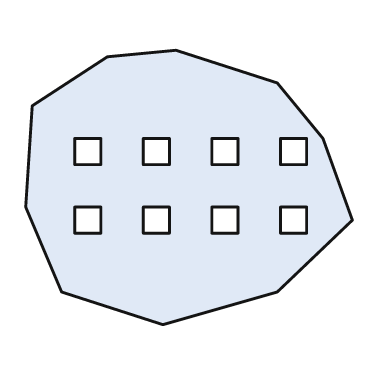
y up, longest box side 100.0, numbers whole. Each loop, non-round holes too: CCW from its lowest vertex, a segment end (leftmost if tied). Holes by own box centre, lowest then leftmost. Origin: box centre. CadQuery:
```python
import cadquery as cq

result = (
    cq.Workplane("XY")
    .moveTo(-8.0, -42.0)
    .lineTo(27.0, -32.0)
    .lineTo(50.0, -10.0)
    .lineTo(41.0, 15.0)
    .lineTo(27.0, 32.0)
    .lineTo(-4.0, 42.0)
    .lineTo(-25.0, 40.0)
    .lineTo(-48.0, 25.0)
    .lineTo(-50.0, -6.0)
    .lineTo(-39.0, -32.0)
    .close()
    .moveTo(-35.0, -14.0)
    .lineTo(-27.0, -14.0)
    .lineTo(-27.0, -6.0)
    .lineTo(-35.0, -6.0)
    .close()
    .moveTo(-14.0, -14.0)
    .lineTo(-6.0, -14.0)
    .lineTo(-6.0, -6.0)
    .lineTo(-14.0, -6.0)
    .close()
    .moveTo(7.0, -14.0)
    .lineTo(15.0, -14.0)
    .lineTo(15.0, -6.0)
    .lineTo(7.0, -6.0)
    .close()
    .moveTo(28.0, -14.0)
    .lineTo(36.0, -14.0)
    .lineTo(36.0, -6.0)
    .lineTo(28.0, -6.0)
    .close()
    .moveTo(-35.0, 7.0)
    .lineTo(-27.0, 7.0)
    .lineTo(-27.0, 15.0)
    .lineTo(-35.0, 15.0)
    .close()
    .moveTo(-14.0, 7.0)
    .lineTo(-6.0, 7.0)
    .lineTo(-6.0, 15.0)
    .lineTo(-14.0, 15.0)
    .close()
    .moveTo(7.0, 7.0)
    .lineTo(15.0, 7.0)
    .lineTo(15.0, 15.0)
    .lineTo(7.0, 15.0)
    .close()
    .moveTo(28.0, 7.0)
    .lineTo(36.0, 7.0)
    .lineTo(36.0, 15.0)
    .lineTo(28.0, 15.0)
    .close()
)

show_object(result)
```